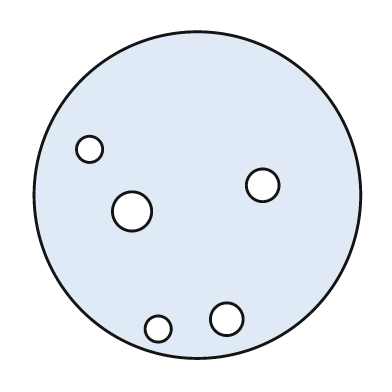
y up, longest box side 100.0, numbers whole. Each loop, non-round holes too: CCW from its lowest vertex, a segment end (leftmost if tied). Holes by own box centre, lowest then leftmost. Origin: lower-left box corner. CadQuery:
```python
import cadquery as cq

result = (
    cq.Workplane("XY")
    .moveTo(50.0, 50.0)
    .circle(50.0)
    .moveTo(38.0, 9.0)
    .circle(4.0)
    .moveTo(59.0, 12.0)
    .circle(5.0)
    .moveTo(30.0, 45.0)
    .circle(6.0)
    .moveTo(70.0, 53.0)
    .circle(5.0)
    .moveTo(17.0, 64.0)
    .circle(4.0)
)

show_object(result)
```